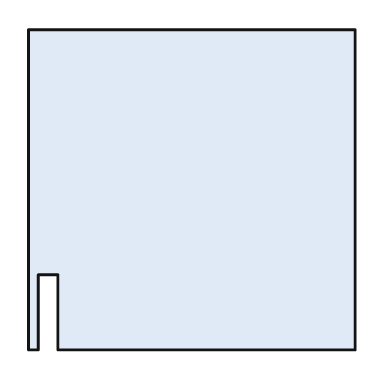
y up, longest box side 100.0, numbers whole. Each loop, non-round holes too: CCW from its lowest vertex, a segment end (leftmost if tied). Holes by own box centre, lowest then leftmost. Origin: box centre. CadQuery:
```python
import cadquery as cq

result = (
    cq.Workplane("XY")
    .moveTo(-50.0, -49.0)
    .lineTo(-47.0, -49.0)
    .lineTo(-47.0, -26.0)
    .lineTo(-41.0, -26.0)
    .lineTo(-41.0, -49.0)
    .lineTo(50.0, -49.0)
    .lineTo(50.0, 49.0)
    .lineTo(-50.0, 49.0)
    .close()
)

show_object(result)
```